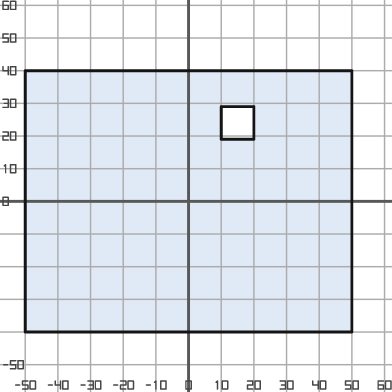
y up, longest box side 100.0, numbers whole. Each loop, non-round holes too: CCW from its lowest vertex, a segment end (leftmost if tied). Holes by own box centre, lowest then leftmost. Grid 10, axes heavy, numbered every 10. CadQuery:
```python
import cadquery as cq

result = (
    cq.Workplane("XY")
    .moveTo(-50.0, -40.0)
    .lineTo(50.0, -40.0)
    .lineTo(50.0, 40.0)
    .lineTo(-50.0, 40.0)
    .close()
    .moveTo(10.0, 19.0)
    .lineTo(20.0, 19.0)
    .lineTo(20.0, 29.0)
    .lineTo(10.0, 29.0)
    .close()
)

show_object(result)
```